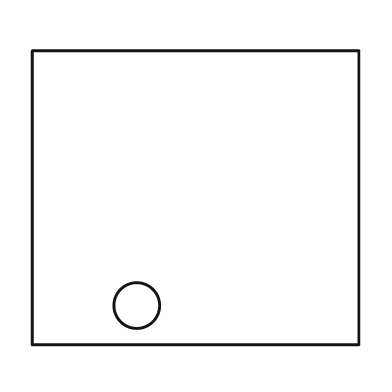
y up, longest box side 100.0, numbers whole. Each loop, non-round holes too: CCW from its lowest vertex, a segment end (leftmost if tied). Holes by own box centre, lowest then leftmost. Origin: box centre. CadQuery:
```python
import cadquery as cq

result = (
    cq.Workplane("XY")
    .moveTo(-50.0, -45.0)
    .lineTo(50.0, -45.0)
    .lineTo(50.0, 45.0)
    .lineTo(-50.0, 45.0)
    .close()
    .moveTo(-18.0, -33.0)
    .circle(7.0)
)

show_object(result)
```